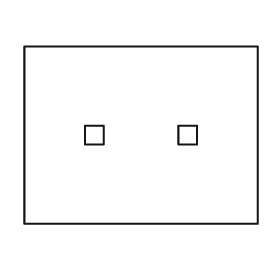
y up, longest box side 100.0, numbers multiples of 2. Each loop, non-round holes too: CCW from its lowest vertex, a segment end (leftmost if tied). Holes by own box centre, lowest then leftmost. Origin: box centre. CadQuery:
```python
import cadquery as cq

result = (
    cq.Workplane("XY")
    .moveTo(-50.0, -38.0)
    .lineTo(50.0, -38.0)
    .lineTo(50.0, 38.0)
    .lineTo(-50.0, 38.0)
    .close()
    .moveTo(-24.0, -4.0)
    .lineTo(-16.0, -4.0)
    .lineTo(-16.0, 4.0)
    .lineTo(-24.0, 4.0)
    .close()
    .moveTo(16.0, -4.0)
    .lineTo(24.0, -4.0)
    .lineTo(24.0, 4.0)
    .lineTo(16.0, 4.0)
    .close()
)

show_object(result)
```